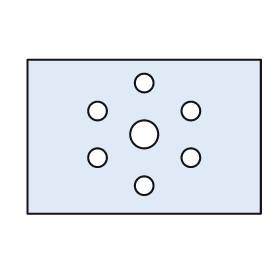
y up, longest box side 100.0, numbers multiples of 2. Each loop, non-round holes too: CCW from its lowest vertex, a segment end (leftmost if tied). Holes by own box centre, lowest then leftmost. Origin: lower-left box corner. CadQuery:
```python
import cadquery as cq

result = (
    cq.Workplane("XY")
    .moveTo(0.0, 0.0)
    .lineTo(100.0, 0.0)
    .lineTo(100.0, 66.0)
    .lineTo(0.0, 66.0)
    .close()
    .moveTo(50.0, 12.0)
    .circle(4.0)
    .moveTo(30.0, 24.0)
    .circle(4.0)
    .moveTo(70.0, 24.0)
    .circle(4.0)
    .moveTo(50.0, 34.0)
    .circle(6.0)
    .moveTo(30.0, 44.0)
    .circle(4.0)
    .moveTo(70.0, 44.0)
    .circle(4.0)
    .moveTo(50.0, 56.0)
    .circle(4.0)
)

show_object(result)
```